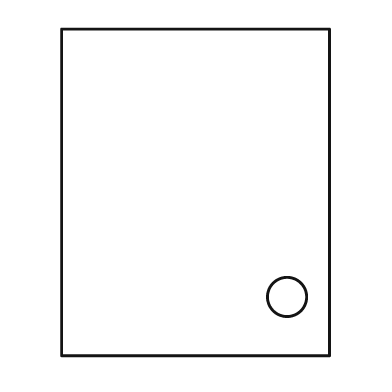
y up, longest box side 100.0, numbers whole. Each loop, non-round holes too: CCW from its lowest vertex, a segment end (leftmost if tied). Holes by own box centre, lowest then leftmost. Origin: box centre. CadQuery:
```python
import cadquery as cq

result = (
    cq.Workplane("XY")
    .moveTo(-41.0, -50.0)
    .lineTo(41.0, -50.0)
    .lineTo(41.0, 50.0)
    .lineTo(-41.0, 50.0)
    .close()
    .moveTo(28.0, -32.0)
    .circle(6.0)
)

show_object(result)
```